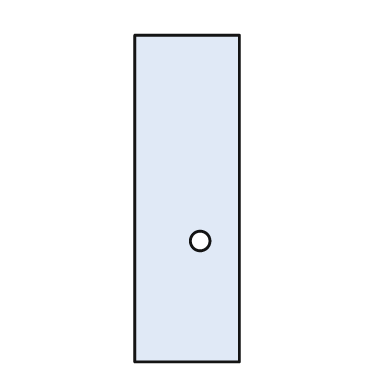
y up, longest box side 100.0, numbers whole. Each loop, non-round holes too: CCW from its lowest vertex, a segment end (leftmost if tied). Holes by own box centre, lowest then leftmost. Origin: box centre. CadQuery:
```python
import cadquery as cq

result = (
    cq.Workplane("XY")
    .moveTo(-16.0, -50.0)
    .lineTo(16.0, -50.0)
    .lineTo(16.0, 50.0)
    .lineTo(-16.0, 50.0)
    .close()
    .moveTo(4.0, -13.0)
    .circle(3.0)
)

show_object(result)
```